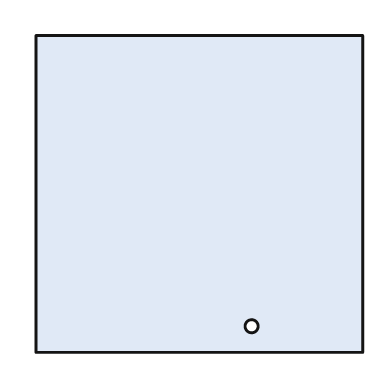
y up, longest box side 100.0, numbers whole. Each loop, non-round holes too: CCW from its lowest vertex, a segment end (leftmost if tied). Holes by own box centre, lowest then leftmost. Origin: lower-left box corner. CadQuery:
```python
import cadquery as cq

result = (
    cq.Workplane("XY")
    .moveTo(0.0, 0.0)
    .lineTo(100.0, 0.0)
    .lineTo(100.0, 97.0)
    .lineTo(0.0, 97.0)
    .close()
    .moveTo(66.0, 8.0)
    .circle(2.0)
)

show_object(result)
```